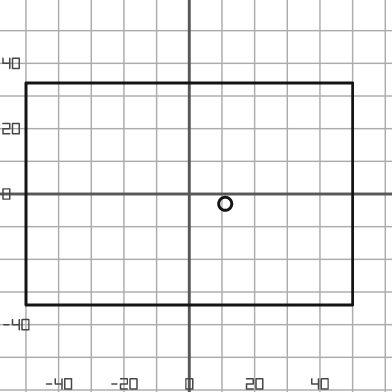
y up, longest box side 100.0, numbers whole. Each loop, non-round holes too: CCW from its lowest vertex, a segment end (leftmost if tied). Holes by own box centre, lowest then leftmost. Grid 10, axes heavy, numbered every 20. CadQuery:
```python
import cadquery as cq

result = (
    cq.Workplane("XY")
    .moveTo(-50.0, -34.0)
    .lineTo(50.0, -34.0)
    .lineTo(50.0, 34.0)
    .lineTo(-50.0, 34.0)
    .close()
    .moveTo(11.0, -3.0)
    .circle(2.0)
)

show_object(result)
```